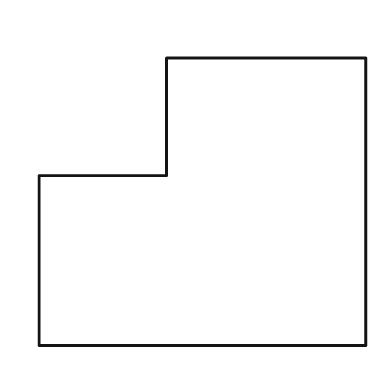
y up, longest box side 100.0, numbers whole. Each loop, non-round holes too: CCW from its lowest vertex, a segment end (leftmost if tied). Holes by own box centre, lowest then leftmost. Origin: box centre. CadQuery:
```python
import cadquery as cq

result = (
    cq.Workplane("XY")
    .moveTo(-50.0, -44.0)
    .lineTo(50.0, -44.0)
    .lineTo(50.0, 44.0)
    .lineTo(-11.0, 44.0)
    .lineTo(-11.0, 8.0)
    .lineTo(-50.0, 8.0)
    .close()
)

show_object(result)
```